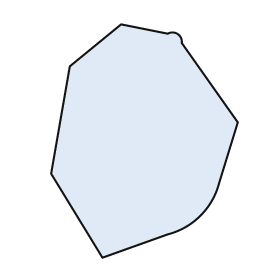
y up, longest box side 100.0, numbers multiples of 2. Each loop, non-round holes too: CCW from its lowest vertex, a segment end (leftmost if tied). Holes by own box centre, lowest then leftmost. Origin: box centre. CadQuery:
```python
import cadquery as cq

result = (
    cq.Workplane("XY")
    .moveTo(-18.0, -50.0)
    .lineTo(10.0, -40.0)
    .threePointArc((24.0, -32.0), (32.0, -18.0))
    .lineTo(40.0, 8.0)
    .lineTo(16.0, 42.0)
    .threePointArc((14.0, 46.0), (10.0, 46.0))
    .lineTo(-10.0, 50.0)
    .lineTo(-32.0, 32.0)
    .lineTo(-40.0, -14.0)
    .close()
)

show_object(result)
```